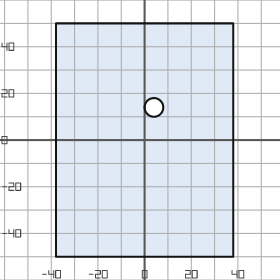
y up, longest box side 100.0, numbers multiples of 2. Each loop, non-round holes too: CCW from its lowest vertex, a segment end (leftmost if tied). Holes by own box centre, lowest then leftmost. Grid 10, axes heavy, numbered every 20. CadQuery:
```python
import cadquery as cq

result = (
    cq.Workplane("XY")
    .moveTo(-38.0, -50.0)
    .lineTo(38.0, -50.0)
    .lineTo(38.0, 50.0)
    .lineTo(-38.0, 50.0)
    .close()
    .moveTo(4.0, 14.0)
    .circle(4.0)
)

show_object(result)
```